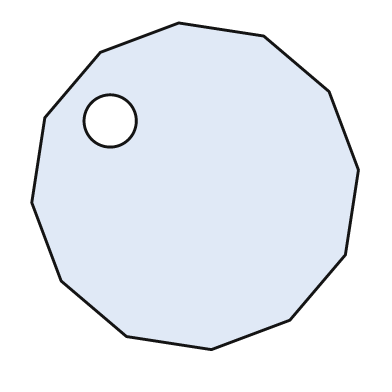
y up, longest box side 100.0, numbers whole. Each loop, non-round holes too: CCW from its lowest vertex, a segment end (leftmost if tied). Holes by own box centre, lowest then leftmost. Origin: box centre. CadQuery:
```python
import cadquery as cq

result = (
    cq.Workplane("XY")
    .moveTo(5.0, -50.0)
    .lineTo(29.0, -41.0)
    .lineTo(46.0, -21.0)
    .lineTo(50.0, 5.0)
    .lineTo(41.0, 29.0)
    .lineTo(21.0, 46.0)
    .lineTo(-5.0, 50.0)
    .lineTo(-29.0, 41.0)
    .lineTo(-46.0, 21.0)
    .lineTo(-50.0, -5.0)
    .lineTo(-41.0, -29.0)
    .lineTo(-21.0, -46.0)
    .close()
    .moveTo(-26.0, 20.0)
    .circle(8.0)
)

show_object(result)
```